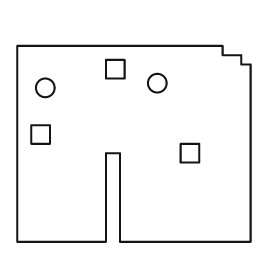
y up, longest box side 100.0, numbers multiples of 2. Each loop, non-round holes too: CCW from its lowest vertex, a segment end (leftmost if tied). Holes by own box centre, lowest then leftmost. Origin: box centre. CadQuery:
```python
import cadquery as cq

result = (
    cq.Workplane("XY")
    .moveTo(-50.0, -42.0)
    .lineTo(-12.0, -42.0)
    .lineTo(-12.0, -4.0)
    .lineTo(-6.0, -4.0)
    .lineTo(-6.0, -42.0)
    .lineTo(50.0, -42.0)
    .lineTo(50.0, 34.0)
    .lineTo(46.0, 34.0)
    .lineTo(46.0, 38.0)
    .lineTo(38.0, 38.0)
    .lineTo(38.0, 42.0)
    .lineTo(-50.0, 42.0)
    .close()
    .moveTo(20.0, -8.0)
    .lineTo(28.0, -8.0)
    .lineTo(28.0, 0.0)
    .lineTo(20.0, 0.0)
    .close()
    .moveTo(-44.0, 0.0)
    .lineTo(-36.0, 0.0)
    .lineTo(-36.0, 8.0)
    .lineTo(-44.0, 8.0)
    .close()
    .moveTo(-38.0, 24.0)
    .circle(4.0)
    .moveTo(10.0, 26.0)
    .circle(4.0)
    .moveTo(-12.0, 28.0)
    .lineTo(-4.0, 28.0)
    .lineTo(-4.0, 36.0)
    .lineTo(-12.0, 36.0)
    .close()
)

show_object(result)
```